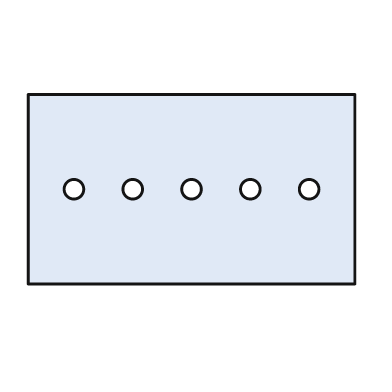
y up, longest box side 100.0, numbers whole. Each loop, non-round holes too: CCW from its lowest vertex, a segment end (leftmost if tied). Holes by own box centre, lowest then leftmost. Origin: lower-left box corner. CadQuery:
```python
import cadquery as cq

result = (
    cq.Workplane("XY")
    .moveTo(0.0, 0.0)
    .lineTo(100.0, 0.0)
    .lineTo(100.0, 58.0)
    .lineTo(0.0, 58.0)
    .close()
    .moveTo(14.0, 29.0)
    .circle(3.0)
    .moveTo(32.0, 29.0)
    .circle(3.0)
    .moveTo(50.0, 29.0)
    .circle(3.0)
    .moveTo(68.0, 29.0)
    .circle(3.0)
    .moveTo(86.0, 29.0)
    .circle(3.0)
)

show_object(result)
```